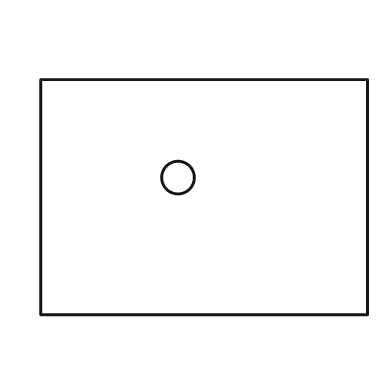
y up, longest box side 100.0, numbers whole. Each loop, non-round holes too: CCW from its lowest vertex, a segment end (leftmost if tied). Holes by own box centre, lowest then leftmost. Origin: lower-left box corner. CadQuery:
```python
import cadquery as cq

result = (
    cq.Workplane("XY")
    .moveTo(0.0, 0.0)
    .lineTo(100.0, 0.0)
    .lineTo(100.0, 72.0)
    .lineTo(0.0, 72.0)
    .close()
    .moveTo(42.0, 42.0)
    .circle(5.0)
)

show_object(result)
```